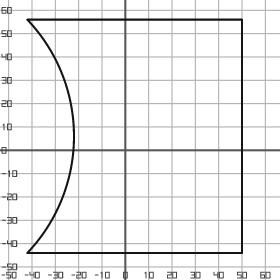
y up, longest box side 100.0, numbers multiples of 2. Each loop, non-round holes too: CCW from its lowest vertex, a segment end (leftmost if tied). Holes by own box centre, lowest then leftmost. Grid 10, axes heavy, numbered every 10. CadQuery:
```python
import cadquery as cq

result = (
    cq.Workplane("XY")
    .moveTo(-42.0, -44.0)
    .lineTo(50.0, -44.0)
    .lineTo(50.0, 56.0)
    .lineTo(-42.0, 56.0)
    .threePointArc((-22.0, 6.0), (-42.0, -44.0))
    .close()
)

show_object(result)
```